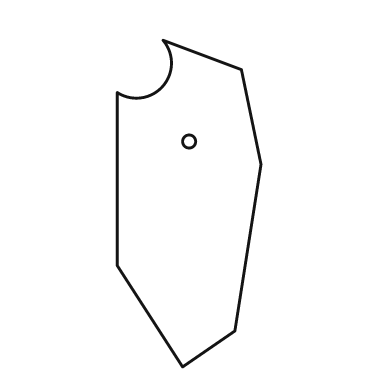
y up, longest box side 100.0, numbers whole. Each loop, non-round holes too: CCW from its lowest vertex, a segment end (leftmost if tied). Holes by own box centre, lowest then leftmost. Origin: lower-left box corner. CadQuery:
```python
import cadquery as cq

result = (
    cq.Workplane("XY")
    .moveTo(20.0, 0.0)
    .lineTo(36.0, 11.0)
    .lineTo(44.0, 62.0)
    .lineTo(38.0, 91.0)
    .lineTo(14.0, 100.0)
    .threePointArc((14.0, 86.0), (0.0, 84.0))
    .lineTo(0.0, 31.0)
    .close()
    .moveTo(22.0, 69.0)
    .circle(2.0)
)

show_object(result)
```